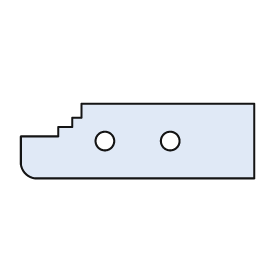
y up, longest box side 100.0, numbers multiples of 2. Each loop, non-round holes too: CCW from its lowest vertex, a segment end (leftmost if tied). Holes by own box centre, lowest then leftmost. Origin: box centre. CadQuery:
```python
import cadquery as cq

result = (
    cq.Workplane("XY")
    .moveTo(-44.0, -16.0)
    .lineTo(50.0, -16.0)
    .lineTo(50.0, 16.0)
    .lineTo(-24.0, 16.0)
    .lineTo(-24.0, 10.0)
    .lineTo(-28.0, 10.0)
    .lineTo(-28.0, 6.0)
    .lineTo(-34.0, 6.0)
    .lineTo(-34.0, 2.0)
    .lineTo(-50.0, 2.0)
    .lineTo(-50.0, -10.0)
    .threePointArc((-48.0, -14.0), (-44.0, -16.0))
    .close()
    .moveTo(-14.0, 0.0)
    .circle(4.0)
    .moveTo(14.0, 0.0)
    .circle(4.0)
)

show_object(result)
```